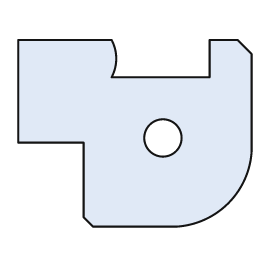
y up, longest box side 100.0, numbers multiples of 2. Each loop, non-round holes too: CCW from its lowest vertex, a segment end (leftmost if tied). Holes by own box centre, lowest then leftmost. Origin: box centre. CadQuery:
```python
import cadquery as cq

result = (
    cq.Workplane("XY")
    .moveTo(-18.0, -40.0)
    .lineTo(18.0, -40.0)
    .threePointArc((40.0, -30.0), (50.0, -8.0))
    .lineTo(50.0, 34.0)
    .lineTo(44.0, 40.0)
    .lineTo(32.0, 40.0)
    .lineTo(32.0, 24.0)
    .lineTo(-10.0, 24.0)
    .threePointArc((-8.0, 32.0), (-10.0, 40.0))
    .lineTo(-50.0, 40.0)
    .lineTo(-50.0, -4.0)
    .lineTo(-22.0, -4.0)
    .lineTo(-22.0, -36.0)
    .close()
    .moveTo(12.0, -2.0)
    .circle(8.0)
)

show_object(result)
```